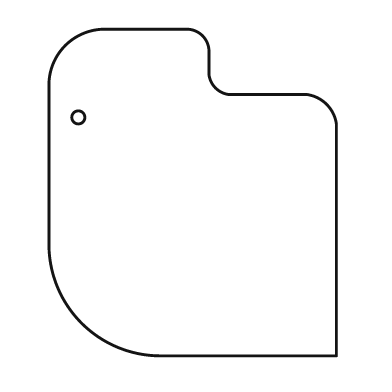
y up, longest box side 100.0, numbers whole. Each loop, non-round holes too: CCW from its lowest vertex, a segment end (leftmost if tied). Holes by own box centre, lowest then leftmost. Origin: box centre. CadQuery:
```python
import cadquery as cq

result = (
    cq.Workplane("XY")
    .moveTo(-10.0, -50.0)
    .lineTo(44.0, -50.0)
    .lineTo(44.0, 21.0)
    .threePointArc((41.0, 27.0), (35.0, 30.0))
    .lineTo(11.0, 30.0)
    .threePointArc((7.0, 32.0), (5.0, 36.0))
    .lineTo(5.0, 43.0)
    .threePointArc((3.0, 48.0), (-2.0, 50.0))
    .lineTo(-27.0, 50.0)
    .threePointArc((-39.0, 45.0), (-44.0, 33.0))
    .lineTo(-44.0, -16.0)
    .threePointArc((-34.0, -40.0), (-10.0, -50.0))
    .close()
    .moveTo(-35.0, 23.0)
    .circle(2.0)
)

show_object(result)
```